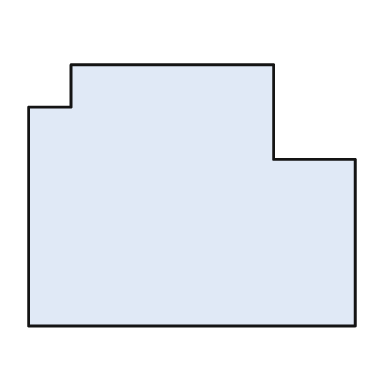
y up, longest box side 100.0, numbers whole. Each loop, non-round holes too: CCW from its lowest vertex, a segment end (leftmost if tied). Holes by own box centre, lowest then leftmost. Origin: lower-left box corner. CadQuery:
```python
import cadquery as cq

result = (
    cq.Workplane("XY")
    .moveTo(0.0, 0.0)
    .lineTo(100.0, 0.0)
    .lineTo(100.0, 51.0)
    .lineTo(75.0, 51.0)
    .lineTo(75.0, 80.0)
    .lineTo(13.0, 80.0)
    .lineTo(13.0, 67.0)
    .lineTo(0.0, 67.0)
    .close()
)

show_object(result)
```